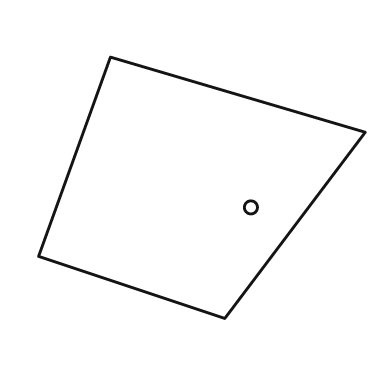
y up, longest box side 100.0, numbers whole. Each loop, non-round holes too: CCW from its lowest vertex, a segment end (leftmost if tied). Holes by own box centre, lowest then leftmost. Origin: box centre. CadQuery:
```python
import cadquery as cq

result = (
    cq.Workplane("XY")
    .moveTo(7.0, -40.0)
    .lineTo(50.0, 17.0)
    .lineTo(-28.0, 40.0)
    .lineTo(-50.0, -21.0)
    .close()
    .moveTo(15.0, -6.0)
    .circle(2.0)
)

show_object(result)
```